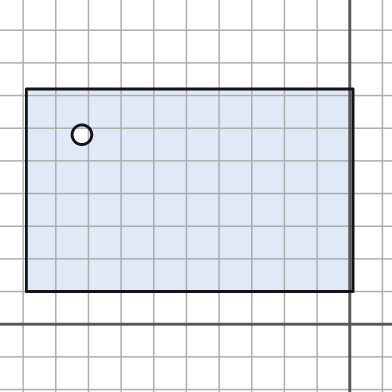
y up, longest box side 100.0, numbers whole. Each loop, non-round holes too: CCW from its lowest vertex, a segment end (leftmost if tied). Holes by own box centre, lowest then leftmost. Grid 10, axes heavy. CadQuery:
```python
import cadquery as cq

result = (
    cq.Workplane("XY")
    .moveTo(-99.0, 10.0)
    .lineTo(1.0, 10.0)
    .lineTo(1.0, 72.0)
    .lineTo(-99.0, 72.0)
    .close()
    .moveTo(-82.0, 58.0)
    .circle(3.0)
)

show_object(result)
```